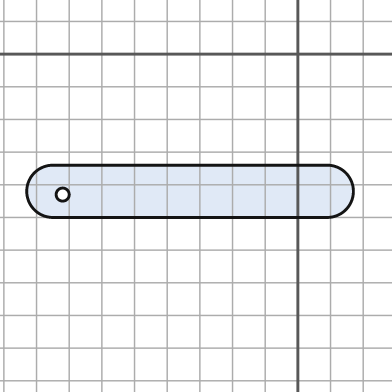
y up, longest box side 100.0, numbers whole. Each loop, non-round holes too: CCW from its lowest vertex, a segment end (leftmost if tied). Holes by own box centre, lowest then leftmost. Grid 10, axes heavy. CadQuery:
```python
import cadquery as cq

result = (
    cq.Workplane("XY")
    .moveTo(-75.0, -50.0)
    .lineTo(9.0, -50.0)
    .threePointArc((17.0, -42.0), (9.0, -34.0))
    .lineTo(-75.0, -34.0)
    .threePointArc((-83.0, -42.0), (-75.0, -50.0))
    .close()
    .moveTo(-72.0, -43.0)
    .circle(2.0)
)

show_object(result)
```